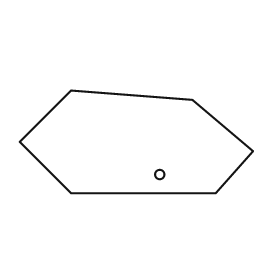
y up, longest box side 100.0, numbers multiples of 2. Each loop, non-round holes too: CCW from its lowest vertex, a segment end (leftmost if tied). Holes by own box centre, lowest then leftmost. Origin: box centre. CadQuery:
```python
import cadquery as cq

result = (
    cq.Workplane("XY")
    .moveTo(-28.0, -22.0)
    .lineTo(34.0, -22.0)
    .lineTo(50.0, -4.0)
    .lineTo(24.0, 18.0)
    .lineTo(-28.0, 22.0)
    .lineTo(-50.0, 0.0)
    .close()
    .moveTo(10.0, -14.0)
    .circle(2.0)
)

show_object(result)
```